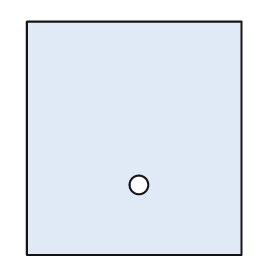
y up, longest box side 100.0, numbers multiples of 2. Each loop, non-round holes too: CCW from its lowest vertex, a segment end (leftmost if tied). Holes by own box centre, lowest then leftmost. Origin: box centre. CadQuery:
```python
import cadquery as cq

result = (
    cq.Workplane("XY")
    .moveTo(-46.0, -50.0)
    .lineTo(46.0, -50.0)
    .lineTo(46.0, 50.0)
    .lineTo(-46.0, 50.0)
    .close()
    .moveTo(2.0, -20.0)
    .circle(4.0)
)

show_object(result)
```